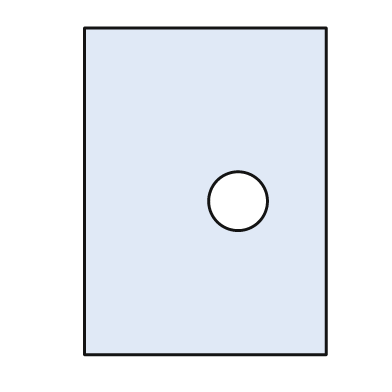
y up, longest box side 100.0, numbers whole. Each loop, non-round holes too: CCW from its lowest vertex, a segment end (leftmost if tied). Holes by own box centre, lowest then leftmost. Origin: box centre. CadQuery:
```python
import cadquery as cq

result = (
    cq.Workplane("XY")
    .moveTo(-37.0, -50.0)
    .lineTo(37.0, -50.0)
    .lineTo(37.0, 50.0)
    .lineTo(-37.0, 50.0)
    .close()
    .moveTo(10.0, -3.0)
    .circle(9.0)
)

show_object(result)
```